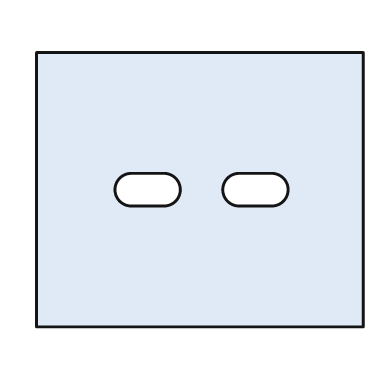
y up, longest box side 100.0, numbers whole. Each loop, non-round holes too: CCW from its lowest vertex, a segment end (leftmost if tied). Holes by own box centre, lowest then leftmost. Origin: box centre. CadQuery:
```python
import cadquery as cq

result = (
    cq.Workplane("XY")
    .moveTo(-50.0, -42.0)
    .lineTo(50.0, -42.0)
    .lineTo(50.0, 42.0)
    .lineTo(-50.0, 42.0)
    .close()
    .moveTo(-21.0, -5.0)
    .lineTo(-11.0, -5.0)
    .threePointArc((-6.0, 0.0), (-11.0, 5.0))
    .lineTo(-21.0, 5.0)
    .threePointArc((-26.0, 0.0), (-21.0, -5.0))
    .close()
    .moveTo(12.0, -5.0)
    .lineTo(22.0, -5.0)
    .threePointArc((27.0, 0.0), (22.0, 5.0))
    .lineTo(12.0, 5.0)
    .threePointArc((7.0, 0.0), (12.0, -5.0))
    .close()
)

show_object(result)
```